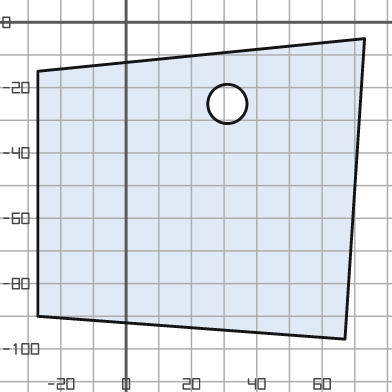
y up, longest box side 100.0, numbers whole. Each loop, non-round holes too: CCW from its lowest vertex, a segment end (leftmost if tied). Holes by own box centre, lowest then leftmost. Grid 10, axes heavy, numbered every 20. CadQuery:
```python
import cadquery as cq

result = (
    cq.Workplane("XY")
    .moveTo(67.0, -97.0)
    .lineTo(73.0, -5.0)
    .lineTo(-27.0, -15.0)
    .lineTo(-27.0, -90.0)
    .close()
    .moveTo(31.0, -25.0)
    .circle(6.0)
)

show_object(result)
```